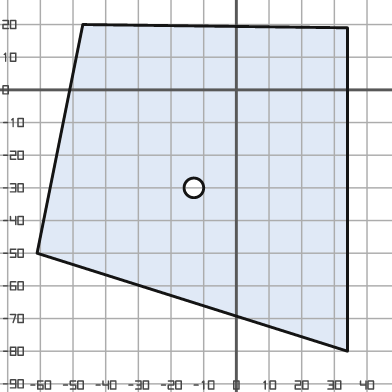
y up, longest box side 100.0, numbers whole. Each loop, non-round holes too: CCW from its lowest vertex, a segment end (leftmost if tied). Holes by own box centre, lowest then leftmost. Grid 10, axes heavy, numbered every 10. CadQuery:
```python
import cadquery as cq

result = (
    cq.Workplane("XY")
    .moveTo(34.0, -80.0)
    .lineTo(34.0, 19.0)
    .lineTo(-47.0, 20.0)
    .lineTo(-61.0, -50.0)
    .close()
    .moveTo(-13.0, -30.0)
    .circle(3.0)
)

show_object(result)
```